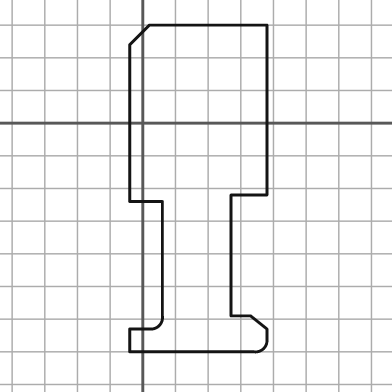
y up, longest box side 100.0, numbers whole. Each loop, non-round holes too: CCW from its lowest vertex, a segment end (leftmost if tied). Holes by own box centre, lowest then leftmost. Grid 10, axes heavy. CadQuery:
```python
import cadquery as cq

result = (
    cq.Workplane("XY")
    .moveTo(-4.0, -70.0)
    .lineTo(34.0, -70.0)
    .threePointArc((37.0, -69.0), (38.0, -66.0))
    .lineTo(38.0, -63.0)
    .lineTo(33.0, -59.0)
    .lineTo(27.0, -59.0)
    .lineTo(27.0, -22.0)
    .lineTo(38.0, -22.0)
    .lineTo(38.0, 30.0)
    .lineTo(2.0, 30.0)
    .lineTo(-4.0, 24.0)
    .lineTo(-4.0, -24.0)
    .lineTo(6.0, -24.0)
    .lineTo(6.0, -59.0)
    .threePointArc((5.0, -62.0), (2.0, -63.0))
    .lineTo(-4.0, -63.0)
    .close()
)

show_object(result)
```